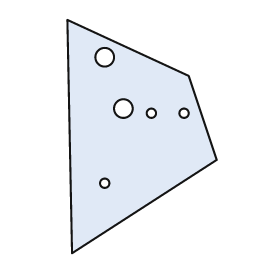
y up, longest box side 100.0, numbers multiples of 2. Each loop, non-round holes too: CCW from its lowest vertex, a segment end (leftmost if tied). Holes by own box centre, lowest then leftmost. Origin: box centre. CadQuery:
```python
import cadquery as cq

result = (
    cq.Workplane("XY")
    .moveTo(-30.0, -50.0)
    .lineTo(32.0, -10.0)
    .lineTo(20.0, 26.0)
    .lineTo(-32.0, 50.0)
    .close()
    .moveTo(-16.0, -20.0)
    .circle(2.0)
    .moveTo(4.0, 10.0)
    .circle(2.0)
    .moveTo(18.0, 10.0)
    .circle(2.0)
    .moveTo(-8.0, 12.0)
    .circle(4.0)
    .moveTo(-16.0, 34.0)
    .circle(4.0)
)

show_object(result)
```